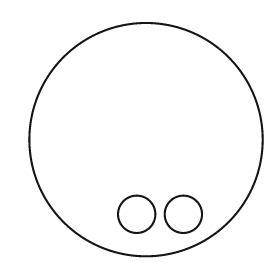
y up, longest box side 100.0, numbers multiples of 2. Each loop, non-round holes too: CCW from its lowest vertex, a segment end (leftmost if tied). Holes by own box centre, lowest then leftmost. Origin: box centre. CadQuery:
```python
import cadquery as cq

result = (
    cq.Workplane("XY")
    .moveTo(0.0, 0.0)
    .circle(50.0)
    .moveTo(-4.0, -32.0)
    .circle(8.0)
    .moveTo(16.0, -32.0)
    .circle(8.0)
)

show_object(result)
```